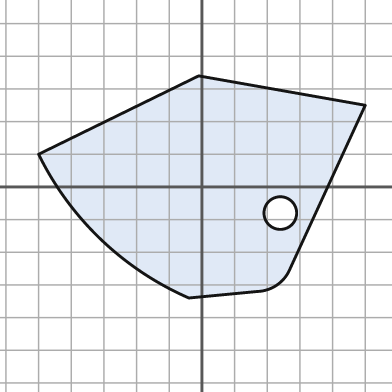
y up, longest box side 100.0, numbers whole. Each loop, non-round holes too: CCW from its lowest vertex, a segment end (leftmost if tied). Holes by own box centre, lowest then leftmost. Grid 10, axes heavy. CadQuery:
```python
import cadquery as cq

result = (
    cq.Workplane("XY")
    .moveTo(-4.0, -34.0)
    .lineTo(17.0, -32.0)
    .threePointArc((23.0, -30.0), (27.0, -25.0))
    .lineTo(50.0, 25.0)
    .lineTo(-1.0, 34.0)
    .lineTo(-50.0, 10.0)
    .threePointArc((-31.0, -16.0), (-4.0, -34.0))
    .close()
    .moveTo(24.0, -8.0)
    .circle(5.0)
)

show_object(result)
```